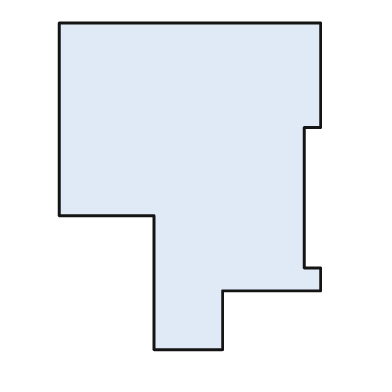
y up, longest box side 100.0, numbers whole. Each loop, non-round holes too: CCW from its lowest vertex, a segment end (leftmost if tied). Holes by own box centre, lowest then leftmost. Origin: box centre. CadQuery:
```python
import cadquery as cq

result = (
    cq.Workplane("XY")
    .moveTo(-11.0, -50.0)
    .lineTo(10.0, -50.0)
    .lineTo(10.0, -32.0)
    .lineTo(40.0, -32.0)
    .lineTo(40.0, -25.0)
    .lineTo(35.0, -25.0)
    .lineTo(35.0, 18.0)
    .lineTo(40.0, 18.0)
    .lineTo(40.0, 50.0)
    .lineTo(-40.0, 50.0)
    .lineTo(-40.0, -9.0)
    .lineTo(-11.0, -9.0)
    .close()
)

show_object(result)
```